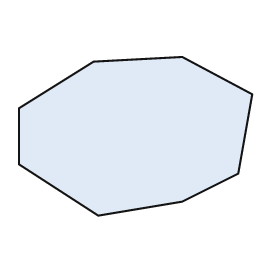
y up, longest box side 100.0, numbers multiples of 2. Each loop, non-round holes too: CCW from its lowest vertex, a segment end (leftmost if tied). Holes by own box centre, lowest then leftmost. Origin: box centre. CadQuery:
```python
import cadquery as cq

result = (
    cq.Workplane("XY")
    .moveTo(-16.0, -34.0)
    .lineTo(20.0, -28.0)
    .lineTo(44.0, -16.0)
    .lineTo(50.0, 18.0)
    .lineTo(20.0, 34.0)
    .lineTo(-18.0, 32.0)
    .lineTo(-50.0, 12.0)
    .lineTo(-50.0, -12.0)
    .close()
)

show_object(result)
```